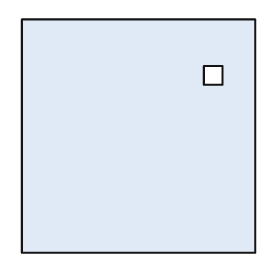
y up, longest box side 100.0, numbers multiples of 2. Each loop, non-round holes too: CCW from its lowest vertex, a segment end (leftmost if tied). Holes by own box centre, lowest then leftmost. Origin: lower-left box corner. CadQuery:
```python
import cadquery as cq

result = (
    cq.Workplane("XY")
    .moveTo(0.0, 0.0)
    .lineTo(100.0, 0.0)
    .lineTo(100.0, 100.0)
    .lineTo(0.0, 100.0)
    .close()
    .moveTo(78.0, 72.0)
    .lineTo(86.0, 72.0)
    .lineTo(86.0, 80.0)
    .lineTo(78.0, 80.0)
    .close()
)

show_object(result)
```